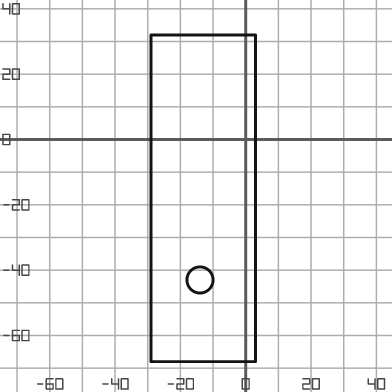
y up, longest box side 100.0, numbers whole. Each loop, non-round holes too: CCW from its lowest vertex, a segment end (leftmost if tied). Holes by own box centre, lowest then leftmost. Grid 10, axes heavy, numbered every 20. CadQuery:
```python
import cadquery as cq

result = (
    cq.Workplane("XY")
    .moveTo(-29.0, -68.0)
    .lineTo(3.0, -68.0)
    .lineTo(3.0, 32.0)
    .lineTo(-29.0, 32.0)
    .close()
    .moveTo(-14.0, -43.0)
    .circle(4.0)
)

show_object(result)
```